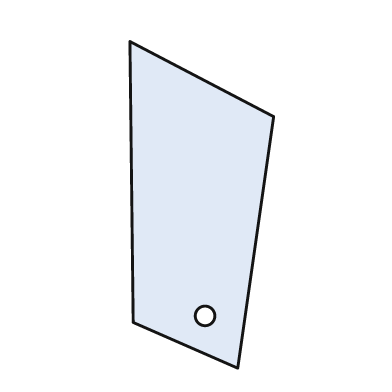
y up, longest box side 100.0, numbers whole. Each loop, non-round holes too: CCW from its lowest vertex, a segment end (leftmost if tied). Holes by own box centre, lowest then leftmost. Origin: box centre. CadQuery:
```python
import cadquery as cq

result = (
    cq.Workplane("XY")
    .moveTo(11.0, -50.0)
    .lineTo(22.0, 27.0)
    .lineTo(-22.0, 50.0)
    .lineTo(-21.0, -36.0)
    .close()
    .moveTo(1.0, -34.0)
    .circle(3.0)
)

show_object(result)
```